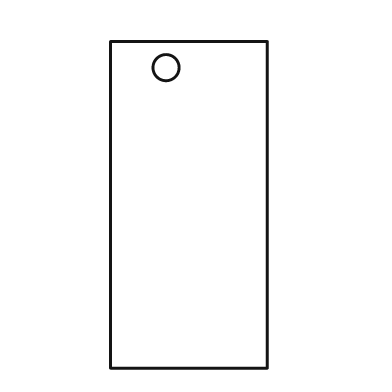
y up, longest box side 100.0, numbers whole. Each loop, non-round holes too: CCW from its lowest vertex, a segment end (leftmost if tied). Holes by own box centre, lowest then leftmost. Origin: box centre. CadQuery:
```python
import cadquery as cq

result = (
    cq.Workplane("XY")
    .moveTo(-24.0, -50.0)
    .lineTo(24.0, -50.0)
    .lineTo(24.0, 50.0)
    .lineTo(-24.0, 50.0)
    .close()
    .moveTo(-7.0, 42.0)
    .circle(4.0)
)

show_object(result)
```